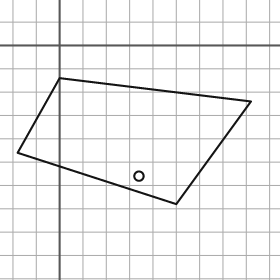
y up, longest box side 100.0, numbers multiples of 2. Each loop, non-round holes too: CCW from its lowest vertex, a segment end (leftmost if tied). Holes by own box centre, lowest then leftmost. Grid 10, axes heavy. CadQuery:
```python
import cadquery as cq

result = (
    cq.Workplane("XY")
    .moveTo(50.0, -68.0)
    .lineTo(82.0, -24.0)
    .lineTo(0.0, -14.0)
    .lineTo(-18.0, -46.0)
    .close()
    .moveTo(34.0, -56.0)
    .circle(2.0)
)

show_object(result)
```